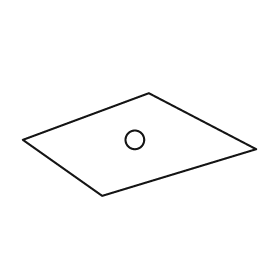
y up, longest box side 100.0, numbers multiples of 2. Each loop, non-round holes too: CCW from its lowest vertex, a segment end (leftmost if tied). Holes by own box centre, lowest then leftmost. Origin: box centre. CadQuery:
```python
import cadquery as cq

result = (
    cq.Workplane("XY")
    .moveTo(-16.0, -22.0)
    .lineTo(50.0, -2.0)
    .lineTo(4.0, 22.0)
    .lineTo(-50.0, 2.0)
    .close()
    .moveTo(-2.0, 2.0)
    .circle(4.0)
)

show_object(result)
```